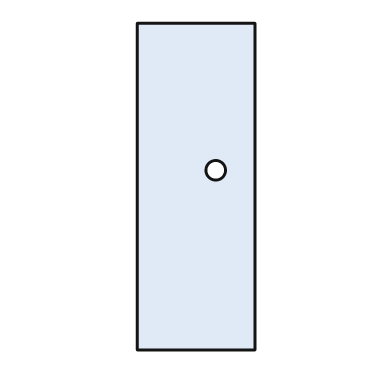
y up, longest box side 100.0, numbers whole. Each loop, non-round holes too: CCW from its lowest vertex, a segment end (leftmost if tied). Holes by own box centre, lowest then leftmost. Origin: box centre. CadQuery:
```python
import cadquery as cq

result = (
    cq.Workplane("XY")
    .moveTo(-18.0, -50.0)
    .lineTo(18.0, -50.0)
    .lineTo(18.0, 50.0)
    .lineTo(-18.0, 50.0)
    .close()
    .moveTo(6.0, 5.0)
    .circle(3.0)
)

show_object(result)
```